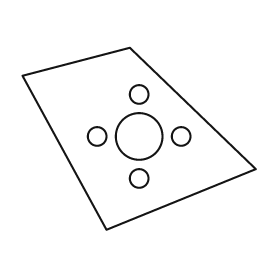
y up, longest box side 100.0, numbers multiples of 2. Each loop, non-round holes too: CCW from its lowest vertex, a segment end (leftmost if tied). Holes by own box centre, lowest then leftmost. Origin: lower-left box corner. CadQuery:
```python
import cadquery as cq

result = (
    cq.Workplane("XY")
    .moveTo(36.0, 0.0)
    .lineTo(100.0, 26.0)
    .lineTo(46.0, 78.0)
    .lineTo(0.0, 66.0)
    .close()
    .moveTo(50.0, 22.0)
    .circle(4.0)
    .moveTo(32.0, 40.0)
    .circle(4.0)
    .moveTo(50.0, 40.0)
    .circle(10.0)
    .moveTo(68.0, 40.0)
    .circle(4.0)
    .moveTo(50.0, 58.0)
    .circle(4.0)
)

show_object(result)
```